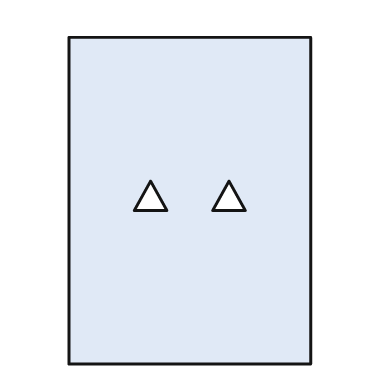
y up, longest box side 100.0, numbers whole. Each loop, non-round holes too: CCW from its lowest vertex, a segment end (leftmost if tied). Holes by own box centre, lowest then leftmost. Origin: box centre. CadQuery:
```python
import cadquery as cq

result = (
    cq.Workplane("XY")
    .moveTo(-37.0, -50.0)
    .lineTo(37.0, -50.0)
    .lineTo(37.0, 50.0)
    .lineTo(-37.0, 50.0)
    .close()
    .moveTo(-17.0, -3.0)
    .lineTo(-7.0, -3.0)
    .lineTo(-12.0, 6.0)
    .close()
    .moveTo(7.0, -3.0)
    .lineTo(17.0, -3.0)
    .lineTo(12.0, 6.0)
    .close()
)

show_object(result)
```